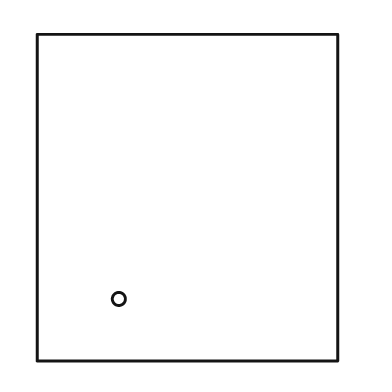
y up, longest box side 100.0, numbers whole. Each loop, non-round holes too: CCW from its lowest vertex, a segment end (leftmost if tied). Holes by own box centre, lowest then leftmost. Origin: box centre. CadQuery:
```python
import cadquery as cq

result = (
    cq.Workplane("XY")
    .moveTo(-46.0, -50.0)
    .lineTo(46.0, -50.0)
    .lineTo(46.0, 50.0)
    .lineTo(-46.0, 50.0)
    .close()
    .moveTo(-21.0, -31.0)
    .circle(2.0)
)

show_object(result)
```